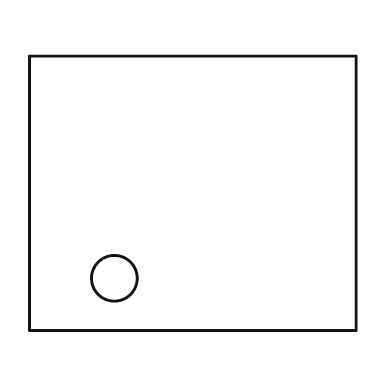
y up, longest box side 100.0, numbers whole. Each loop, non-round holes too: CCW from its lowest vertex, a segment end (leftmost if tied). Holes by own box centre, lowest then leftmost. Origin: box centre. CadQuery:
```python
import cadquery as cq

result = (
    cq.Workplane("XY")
    .moveTo(-50.0, -42.0)
    .lineTo(50.0, -42.0)
    .lineTo(50.0, 42.0)
    .lineTo(-50.0, 42.0)
    .close()
    .moveTo(-24.0, -26.0)
    .circle(7.0)
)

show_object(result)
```